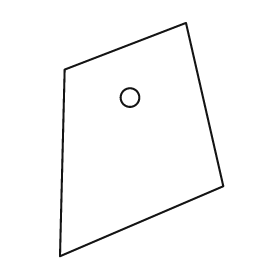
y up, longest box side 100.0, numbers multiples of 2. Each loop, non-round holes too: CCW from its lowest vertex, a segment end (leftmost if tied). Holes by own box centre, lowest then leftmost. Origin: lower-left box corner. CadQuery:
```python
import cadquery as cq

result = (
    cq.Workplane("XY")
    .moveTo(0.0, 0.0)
    .lineTo(70.0, 30.0)
    .lineTo(54.0, 100.0)
    .lineTo(2.0, 80.0)
    .close()
    .moveTo(30.0, 68.0)
    .circle(4.0)
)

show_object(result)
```